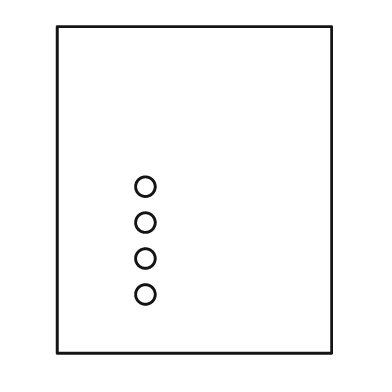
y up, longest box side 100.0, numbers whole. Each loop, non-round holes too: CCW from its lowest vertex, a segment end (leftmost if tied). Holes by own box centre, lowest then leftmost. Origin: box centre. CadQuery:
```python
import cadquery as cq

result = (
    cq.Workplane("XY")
    .moveTo(-42.0, -50.0)
    .lineTo(42.0, -50.0)
    .lineTo(42.0, 50.0)
    .lineTo(-42.0, 50.0)
    .close()
    .moveTo(-15.0, -32.0)
    .circle(3.0)
    .moveTo(-15.0, -21.0)
    .circle(3.0)
    .moveTo(-15.0, -10.0)
    .circle(3.0)
    .moveTo(-15.0, 1.0)
    .circle(3.0)
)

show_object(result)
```